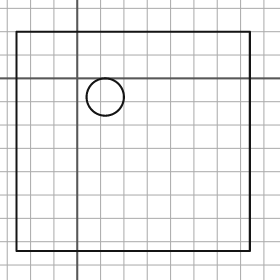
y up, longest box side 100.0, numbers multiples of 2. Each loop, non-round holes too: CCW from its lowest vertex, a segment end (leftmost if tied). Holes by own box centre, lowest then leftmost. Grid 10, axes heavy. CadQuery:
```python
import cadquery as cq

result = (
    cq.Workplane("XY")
    .moveTo(-26.0, -74.0)
    .lineTo(74.0, -74.0)
    .lineTo(74.0, 20.0)
    .lineTo(-26.0, 20.0)
    .close()
    .moveTo(12.0, -8.0)
    .circle(8.0)
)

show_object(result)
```